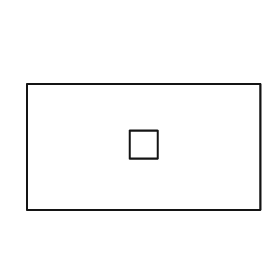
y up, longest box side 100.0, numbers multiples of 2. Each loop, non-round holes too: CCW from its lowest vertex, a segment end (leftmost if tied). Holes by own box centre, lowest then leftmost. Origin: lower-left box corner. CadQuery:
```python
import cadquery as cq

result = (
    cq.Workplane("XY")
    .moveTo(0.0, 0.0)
    .lineTo(100.0, 0.0)
    .lineTo(100.0, 54.0)
    .lineTo(0.0, 54.0)
    .close()
    .moveTo(44.0, 22.0)
    .lineTo(56.0, 22.0)
    .lineTo(56.0, 34.0)
    .lineTo(44.0, 34.0)
    .close()
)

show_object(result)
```